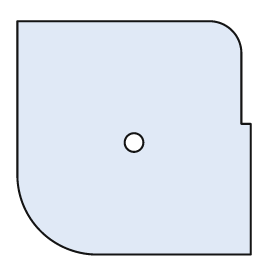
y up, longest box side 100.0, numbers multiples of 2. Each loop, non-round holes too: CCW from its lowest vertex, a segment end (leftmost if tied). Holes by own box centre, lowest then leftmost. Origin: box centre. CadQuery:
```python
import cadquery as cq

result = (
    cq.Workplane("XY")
    .moveTo(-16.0, -50.0)
    .lineTo(50.0, -50.0)
    .lineTo(50.0, 6.0)
    .lineTo(46.0, 6.0)
    .lineTo(46.0, 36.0)
    .threePointArc((42.0, 46.0), (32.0, 50.0))
    .lineTo(-50.0, 50.0)
    .lineTo(-50.0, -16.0)
    .threePointArc((-40.0, -40.0), (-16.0, -50.0))
    .close()
    .moveTo(0.0, -2.0)
    .circle(4.0)
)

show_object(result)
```